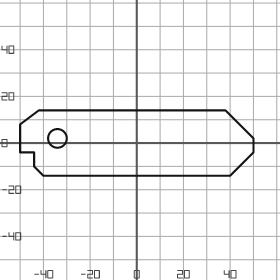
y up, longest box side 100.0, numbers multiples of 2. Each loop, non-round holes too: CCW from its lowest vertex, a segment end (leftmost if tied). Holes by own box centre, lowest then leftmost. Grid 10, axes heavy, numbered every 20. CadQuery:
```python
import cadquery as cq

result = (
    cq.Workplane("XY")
    .moveTo(-40.0, -14.0)
    .lineTo(40.0, -14.0)
    .lineTo(50.0, -4.0)
    .lineTo(50.0, 2.0)
    .lineTo(38.0, 14.0)
    .lineTo(-42.0, 14.0)
    .lineTo(-50.0, 8.0)
    .lineTo(-50.0, -4.0)
    .lineTo(-44.0, -4.0)
    .lineTo(-44.0, -10.0)
    .close()
    .moveTo(-34.0, 2.0)
    .circle(4.0)
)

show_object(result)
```